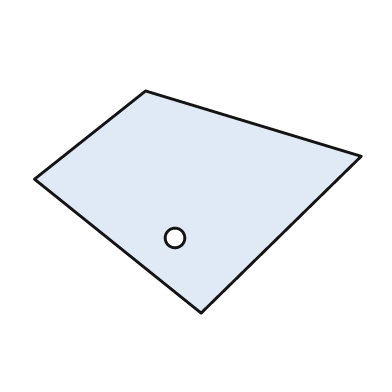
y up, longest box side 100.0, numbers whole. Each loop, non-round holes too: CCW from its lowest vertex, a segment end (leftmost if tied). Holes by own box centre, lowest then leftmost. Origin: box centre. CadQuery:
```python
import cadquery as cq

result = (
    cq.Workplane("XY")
    .moveTo(1.0, -34.0)
    .lineTo(50.0, 14.0)
    .lineTo(-16.0, 34.0)
    .lineTo(-50.0, 7.0)
    .close()
    .moveTo(-7.0, -11.0)
    .circle(3.0)
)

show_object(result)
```